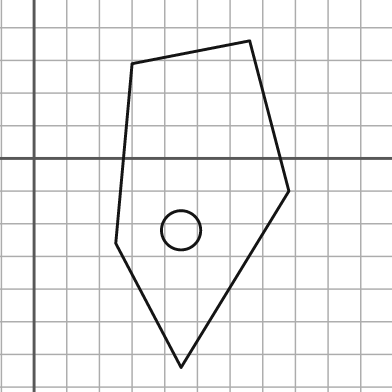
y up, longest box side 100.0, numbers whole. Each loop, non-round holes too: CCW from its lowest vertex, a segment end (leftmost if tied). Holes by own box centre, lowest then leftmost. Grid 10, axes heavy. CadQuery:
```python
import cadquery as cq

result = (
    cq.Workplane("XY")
    .moveTo(45.0, -64.0)
    .lineTo(78.0, -10.0)
    .lineTo(66.0, 36.0)
    .lineTo(30.0, 29.0)
    .lineTo(25.0, -26.0)
    .close()
    .moveTo(45.0, -22.0)
    .circle(6.0)
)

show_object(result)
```